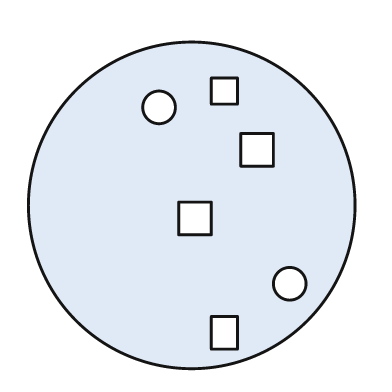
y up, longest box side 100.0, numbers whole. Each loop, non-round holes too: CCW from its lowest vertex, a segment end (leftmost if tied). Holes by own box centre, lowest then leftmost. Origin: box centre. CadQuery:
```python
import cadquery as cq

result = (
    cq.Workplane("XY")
    .moveTo(0.0, 0.0)
    .circle(50.0)
    .moveTo(6.0, -44.0)
    .lineTo(14.0, -44.0)
    .lineTo(14.0, -34.0)
    .lineTo(6.0, -34.0)
    .close()
    .moveTo(30.0, -24.0)
    .circle(5.0)
    .moveTo(-4.0, -9.0)
    .lineTo(6.0, -9.0)
    .lineTo(6.0, 1.0)
    .lineTo(-4.0, 1.0)
    .close()
    .moveTo(15.0, 12.0)
    .lineTo(25.0, 12.0)
    .lineTo(25.0, 22.0)
    .lineTo(15.0, 22.0)
    .close()
    .moveTo(-10.0, 30.0)
    .circle(5.0)
    .moveTo(6.0, 31.0)
    .lineTo(14.0, 31.0)
    .lineTo(14.0, 39.0)
    .lineTo(6.0, 39.0)
    .close()
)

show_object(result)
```